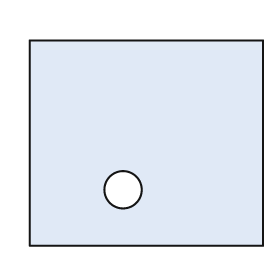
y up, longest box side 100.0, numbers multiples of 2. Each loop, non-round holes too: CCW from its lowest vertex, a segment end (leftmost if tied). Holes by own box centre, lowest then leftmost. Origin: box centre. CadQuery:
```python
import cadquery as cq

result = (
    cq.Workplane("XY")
    .moveTo(-50.0, -44.0)
    .lineTo(50.0, -44.0)
    .lineTo(50.0, 44.0)
    .lineTo(-50.0, 44.0)
    .close()
    .moveTo(-10.0, -20.0)
    .circle(8.0)
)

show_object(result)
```